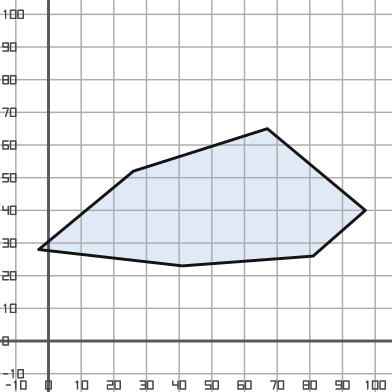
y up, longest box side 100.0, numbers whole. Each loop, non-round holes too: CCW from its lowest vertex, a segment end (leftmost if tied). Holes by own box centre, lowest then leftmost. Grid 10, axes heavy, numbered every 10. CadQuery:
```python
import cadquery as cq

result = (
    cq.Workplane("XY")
    .moveTo(41.0, 23.0)
    .lineTo(81.0, 26.0)
    .lineTo(97.0, 40.0)
    .lineTo(67.0, 65.0)
    .lineTo(26.0, 52.0)
    .lineTo(-3.0, 28.0)
    .close()
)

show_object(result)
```